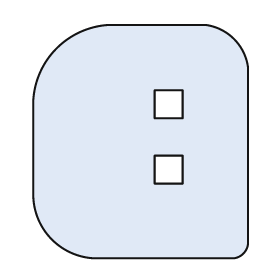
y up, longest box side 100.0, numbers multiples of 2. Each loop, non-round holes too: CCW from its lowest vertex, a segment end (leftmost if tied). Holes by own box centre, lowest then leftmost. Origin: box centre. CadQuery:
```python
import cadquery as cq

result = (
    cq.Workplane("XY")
    .moveTo(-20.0, -50.0)
    .lineTo(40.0, -50.0)
    .threePointArc((44.0, -48.0), (46.0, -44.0))
    .lineTo(46.0, 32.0)
    .threePointArc((40.0, 44.0), (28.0, 50.0))
    .lineTo(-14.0, 50.0)
    .threePointArc((-36.0, 40.0), (-46.0, 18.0))
    .lineTo(-46.0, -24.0)
    .threePointArc((-38.0, -42.0), (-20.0, -50.0))
    .close()
    .moveTo(6.0, -18.0)
    .lineTo(18.0, -18.0)
    .lineTo(18.0, -6.0)
    .lineTo(6.0, -6.0)
    .close()
    .moveTo(6.0, 10.0)
    .lineTo(18.0, 10.0)
    .lineTo(18.0, 22.0)
    .lineTo(6.0, 22.0)
    .close()
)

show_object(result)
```